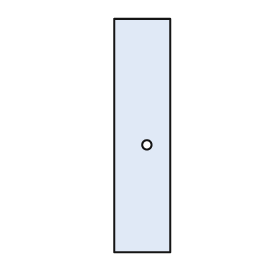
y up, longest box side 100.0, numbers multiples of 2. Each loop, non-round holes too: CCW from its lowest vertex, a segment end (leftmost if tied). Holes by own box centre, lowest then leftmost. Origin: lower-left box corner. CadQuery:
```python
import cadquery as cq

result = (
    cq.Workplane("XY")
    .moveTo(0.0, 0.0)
    .lineTo(24.0, 0.0)
    .lineTo(24.0, 100.0)
    .lineTo(0.0, 100.0)
    .close()
    .moveTo(14.0, 46.0)
    .circle(2.0)
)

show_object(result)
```